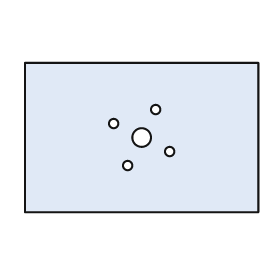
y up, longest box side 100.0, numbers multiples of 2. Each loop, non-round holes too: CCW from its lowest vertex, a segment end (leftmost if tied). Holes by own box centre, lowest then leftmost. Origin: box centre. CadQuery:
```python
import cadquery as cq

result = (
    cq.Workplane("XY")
    .moveTo(-50.0, -32.0)
    .lineTo(50.0, -32.0)
    .lineTo(50.0, 32.0)
    .lineTo(-50.0, 32.0)
    .close()
    .moveTo(-6.0, -12.0)
    .circle(2.0)
    .moveTo(12.0, -6.0)
    .circle(2.0)
    .moveTo(0.0, 0.0)
    .circle(4.0)
    .moveTo(-12.0, 6.0)
    .circle(2.0)
    .moveTo(6.0, 12.0)
    .circle(2.0)
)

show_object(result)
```